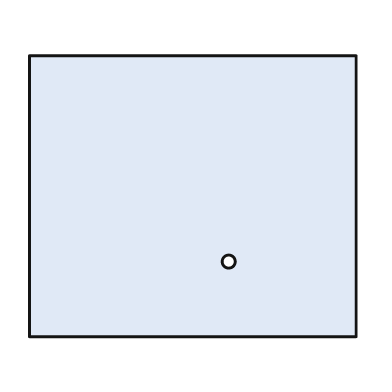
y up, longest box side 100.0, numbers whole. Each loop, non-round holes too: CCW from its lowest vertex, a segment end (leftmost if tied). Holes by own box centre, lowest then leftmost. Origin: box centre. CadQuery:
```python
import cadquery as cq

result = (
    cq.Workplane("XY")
    .moveTo(-50.0, -43.0)
    .lineTo(50.0, -43.0)
    .lineTo(50.0, 43.0)
    .lineTo(-50.0, 43.0)
    .close()
    .moveTo(11.0, -20.0)
    .circle(2.0)
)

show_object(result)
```